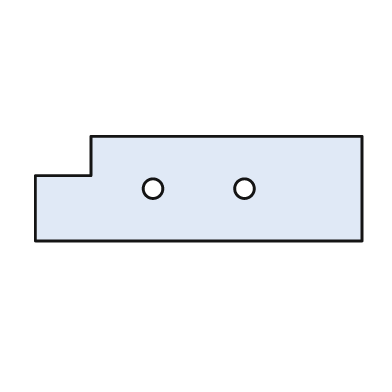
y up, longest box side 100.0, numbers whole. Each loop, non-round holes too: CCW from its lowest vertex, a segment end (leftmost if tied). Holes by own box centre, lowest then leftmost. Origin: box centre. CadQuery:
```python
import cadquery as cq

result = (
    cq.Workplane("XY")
    .moveTo(-50.0, -16.0)
    .lineTo(50.0, -16.0)
    .lineTo(50.0, 16.0)
    .lineTo(-33.0, 16.0)
    .lineTo(-33.0, 4.0)
    .lineTo(-50.0, 4.0)
    .close()
    .moveTo(-14.0, 0.0)
    .circle(3.0)
    .moveTo(14.0, 0.0)
    .circle(3.0)
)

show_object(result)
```